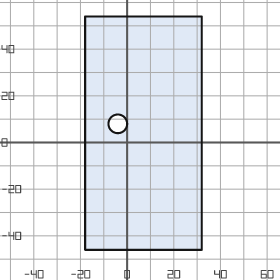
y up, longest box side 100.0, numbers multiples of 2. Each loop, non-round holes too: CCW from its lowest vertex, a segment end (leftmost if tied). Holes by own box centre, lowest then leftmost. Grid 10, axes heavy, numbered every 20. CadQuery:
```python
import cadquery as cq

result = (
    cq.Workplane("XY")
    .moveTo(-18.0, -46.0)
    .lineTo(32.0, -46.0)
    .lineTo(32.0, 54.0)
    .lineTo(-18.0, 54.0)
    .close()
    .moveTo(-4.0, 8.0)
    .circle(4.0)
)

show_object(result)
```